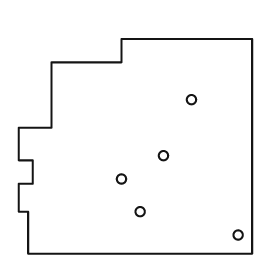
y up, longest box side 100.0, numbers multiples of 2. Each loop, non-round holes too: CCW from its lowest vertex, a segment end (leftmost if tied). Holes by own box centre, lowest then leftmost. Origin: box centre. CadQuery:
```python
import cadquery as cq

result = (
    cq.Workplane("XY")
    .moveTo(-46.0, -46.0)
    .lineTo(50.0, -46.0)
    .lineTo(50.0, 46.0)
    .lineTo(-6.0, 46.0)
    .lineTo(-6.0, 36.0)
    .lineTo(-36.0, 36.0)
    .lineTo(-36.0, 8.0)
    .lineTo(-50.0, 8.0)
    .lineTo(-50.0, -6.0)
    .lineTo(-44.0, -6.0)
    .lineTo(-44.0, -16.0)
    .lineTo(-50.0, -16.0)
    .lineTo(-50.0, -28.0)
    .lineTo(-46.0, -28.0)
    .close()
    .moveTo(44.0, -38.0)
    .circle(2.0)
    .moveTo(2.0, -28.0)
    .circle(2.0)
    .moveTo(-6.0, -14.0)
    .circle(2.0)
    .moveTo(12.0, -4.0)
    .circle(2.0)
    .moveTo(24.0, 20.0)
    .circle(2.0)
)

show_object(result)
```